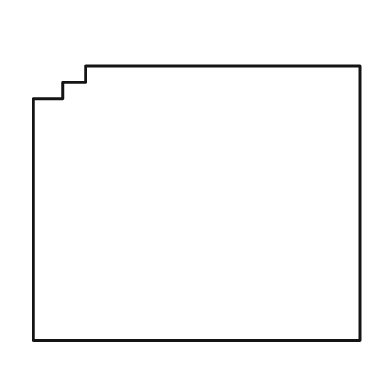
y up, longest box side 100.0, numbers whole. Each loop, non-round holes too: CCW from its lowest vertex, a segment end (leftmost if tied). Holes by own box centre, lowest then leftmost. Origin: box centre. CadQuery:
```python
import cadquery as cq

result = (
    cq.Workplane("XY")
    .moveTo(-50.0, -42.0)
    .lineTo(50.0, -42.0)
    .lineTo(50.0, 42.0)
    .lineTo(-34.0, 42.0)
    .lineTo(-34.0, 37.0)
    .lineTo(-41.0, 37.0)
    .lineTo(-41.0, 32.0)
    .lineTo(-50.0, 32.0)
    .close()
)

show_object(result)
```